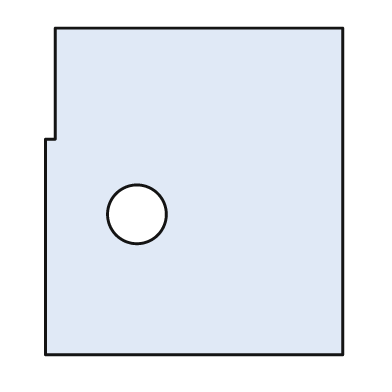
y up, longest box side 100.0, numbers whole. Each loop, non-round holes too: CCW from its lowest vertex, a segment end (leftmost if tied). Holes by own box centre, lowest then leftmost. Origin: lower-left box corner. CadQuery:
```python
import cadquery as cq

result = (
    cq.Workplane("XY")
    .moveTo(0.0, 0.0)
    .lineTo(91.0, 0.0)
    .lineTo(91.0, 100.0)
    .lineTo(3.0, 100.0)
    .lineTo(3.0, 66.0)
    .lineTo(0.0, 66.0)
    .close()
    .moveTo(28.0, 43.0)
    .circle(9.0)
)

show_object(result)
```